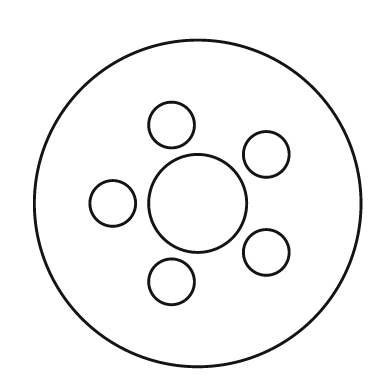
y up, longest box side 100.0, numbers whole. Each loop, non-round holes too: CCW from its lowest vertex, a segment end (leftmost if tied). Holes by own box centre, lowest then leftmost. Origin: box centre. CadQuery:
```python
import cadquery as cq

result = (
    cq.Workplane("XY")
    .moveTo(0.0, 0.0)
    .circle(50.0)
    .moveTo(-8.0, -24.0)
    .circle(7.0)
    .moveTo(21.0, -15.0)
    .circle(7.0)
    .moveTo(-26.0, 0.0)
    .circle(7.0)
    .moveTo(0.0, 0.0)
    .circle(15.0)
    .moveTo(21.0, 15.0)
    .circle(7.0)
    .moveTo(-8.0, 24.0)
    .circle(7.0)
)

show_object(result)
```